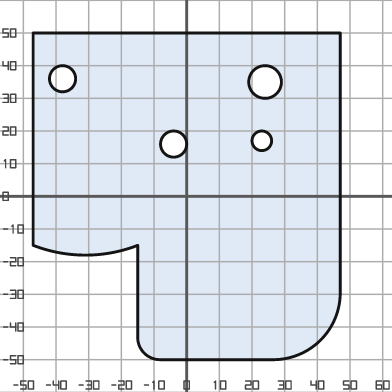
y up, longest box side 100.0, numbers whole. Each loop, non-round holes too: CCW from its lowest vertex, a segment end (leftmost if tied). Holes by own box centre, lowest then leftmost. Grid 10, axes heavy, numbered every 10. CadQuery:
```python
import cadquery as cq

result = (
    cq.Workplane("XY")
    .moveTo(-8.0, -50.0)
    .lineTo(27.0, -50.0)
    .threePointArc((41.0, -44.0), (47.0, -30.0))
    .lineTo(47.0, 50.0)
    .lineTo(-47.0, 50.0)
    .lineTo(-47.0, -15.0)
    .threePointArc((-31.0, -18.0), (-15.0, -15.0))
    .lineTo(-15.0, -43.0)
    .threePointArc((-13.0, -48.0), (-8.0, -50.0))
    .close()
    .moveTo(-4.0, 16.0)
    .circle(4.0)
    .moveTo(23.0, 17.0)
    .circle(3.0)
    .moveTo(24.0, 35.0)
    .circle(5.0)
    .moveTo(-38.0, 36.0)
    .circle(4.0)
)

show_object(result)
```